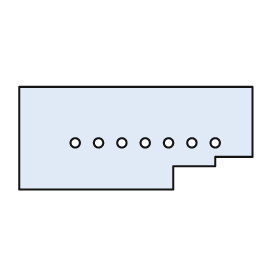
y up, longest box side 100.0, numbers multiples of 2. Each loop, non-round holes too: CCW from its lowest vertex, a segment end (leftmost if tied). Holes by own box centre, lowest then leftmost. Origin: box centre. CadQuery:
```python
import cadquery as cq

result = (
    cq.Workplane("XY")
    .moveTo(-50.0, -22.0)
    .lineTo(16.0, -22.0)
    .lineTo(16.0, -12.0)
    .lineTo(34.0, -12.0)
    .lineTo(34.0, -8.0)
    .lineTo(50.0, -8.0)
    .lineTo(50.0, 22.0)
    .lineTo(-50.0, 22.0)
    .close()
    .moveTo(-26.0, -2.0)
    .circle(2.0)
    .moveTo(-16.0, -2.0)
    .circle(2.0)
    .moveTo(-6.0, -2.0)
    .circle(2.0)
    .moveTo(4.0, -2.0)
    .circle(2.0)
    .moveTo(14.0, -2.0)
    .circle(2.0)
    .moveTo(24.0, -2.0)
    .circle(2.0)
    .moveTo(34.0, -2.0)
    .circle(2.0)
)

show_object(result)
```